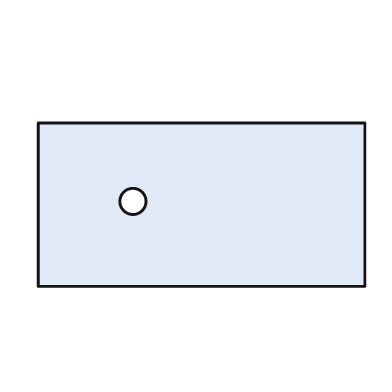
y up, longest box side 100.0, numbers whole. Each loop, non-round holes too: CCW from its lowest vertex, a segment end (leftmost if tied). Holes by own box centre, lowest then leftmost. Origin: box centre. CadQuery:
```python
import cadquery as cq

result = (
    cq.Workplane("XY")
    .moveTo(-50.0, -25.0)
    .lineTo(50.0, -25.0)
    .lineTo(50.0, 25.0)
    .lineTo(-50.0, 25.0)
    .close()
    .moveTo(-21.0, 1.0)
    .circle(4.0)
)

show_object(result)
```